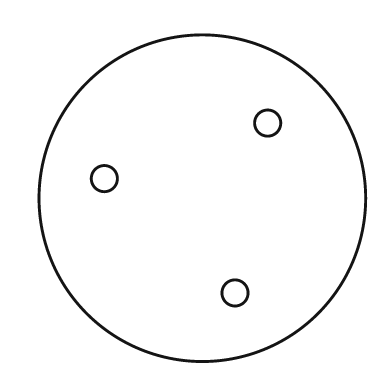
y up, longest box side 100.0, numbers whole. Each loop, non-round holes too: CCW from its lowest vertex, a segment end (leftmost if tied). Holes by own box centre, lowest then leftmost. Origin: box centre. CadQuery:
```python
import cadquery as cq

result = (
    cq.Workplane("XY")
    .moveTo(0.0, 0.0)
    .circle(50.0)
    .moveTo(10.0, -29.0)
    .circle(4.0)
    .moveTo(-30.0, 6.0)
    .circle(4.0)
    .moveTo(20.0, 23.0)
    .circle(4.0)
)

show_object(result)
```